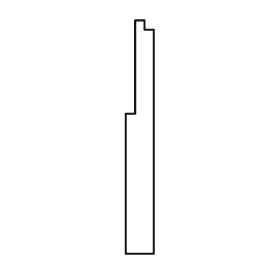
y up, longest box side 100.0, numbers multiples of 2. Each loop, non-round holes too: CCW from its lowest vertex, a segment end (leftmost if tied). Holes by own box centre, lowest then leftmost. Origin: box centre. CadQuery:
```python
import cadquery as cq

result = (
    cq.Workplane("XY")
    .moveTo(-6.0, -50.0)
    .lineTo(6.0, -50.0)
    .lineTo(6.0, 46.0)
    .lineTo(2.0, 46.0)
    .lineTo(2.0, 50.0)
    .lineTo(-2.0, 50.0)
    .lineTo(-2.0, 10.0)
    .lineTo(-6.0, 10.0)
    .close()
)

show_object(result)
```